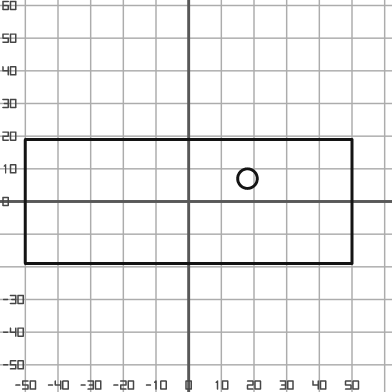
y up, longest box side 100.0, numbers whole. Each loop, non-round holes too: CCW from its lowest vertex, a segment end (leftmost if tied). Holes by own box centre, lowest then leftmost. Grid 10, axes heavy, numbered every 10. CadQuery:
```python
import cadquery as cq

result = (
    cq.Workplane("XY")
    .moveTo(-50.0, -19.0)
    .lineTo(50.0, -19.0)
    .lineTo(50.0, 19.0)
    .lineTo(-50.0, 19.0)
    .close()
    .moveTo(18.0, 7.0)
    .circle(3.0)
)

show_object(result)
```